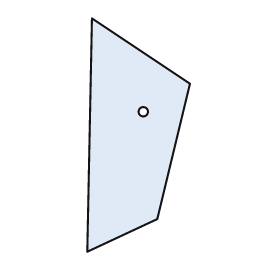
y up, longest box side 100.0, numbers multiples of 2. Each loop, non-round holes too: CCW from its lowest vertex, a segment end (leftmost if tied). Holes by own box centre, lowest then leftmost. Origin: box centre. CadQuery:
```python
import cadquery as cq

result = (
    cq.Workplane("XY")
    .moveTo(-22.0, -50.0)
    .lineTo(8.0, -36.0)
    .lineTo(22.0, 22.0)
    .lineTo(-20.0, 50.0)
    .close()
    .moveTo(2.0, 10.0)
    .circle(2.0)
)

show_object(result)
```